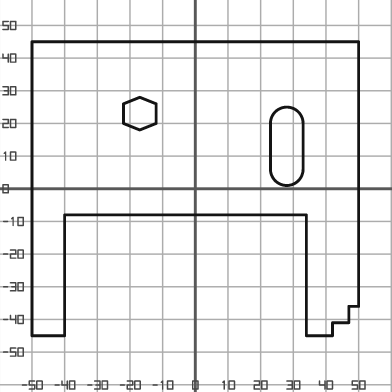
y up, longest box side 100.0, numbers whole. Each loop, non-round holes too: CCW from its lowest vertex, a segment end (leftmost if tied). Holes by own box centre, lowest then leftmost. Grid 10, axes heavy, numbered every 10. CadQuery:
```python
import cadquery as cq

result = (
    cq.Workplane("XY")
    .moveTo(-50.0, -45.0)
    .lineTo(-40.0, -45.0)
    .lineTo(-40.0, -8.0)
    .lineTo(34.0, -8.0)
    .lineTo(34.0, -45.0)
    .lineTo(42.0, -45.0)
    .lineTo(42.0, -41.0)
    .lineTo(47.0, -41.0)
    .lineTo(47.0, -36.0)
    .lineTo(50.0, -36.0)
    .lineTo(50.0, 45.0)
    .lineTo(-50.0, 45.0)
    .close()
    .moveTo(23.0, 6.0)
    .threePointArc((28.0, 1.0), (33.0, 6.0))
    .lineTo(33.0, 20.0)
    .threePointArc((28.0, 25.0), (23.0, 20.0))
    .close()
    .moveTo(-17.0, 18.0)
    .lineTo(-12.0, 20.0)
    .lineTo(-12.0, 26.0)
    .lineTo(-17.0, 28.0)
    .lineTo(-22.0, 26.0)
    .lineTo(-22.0, 20.0)
    .close()
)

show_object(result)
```